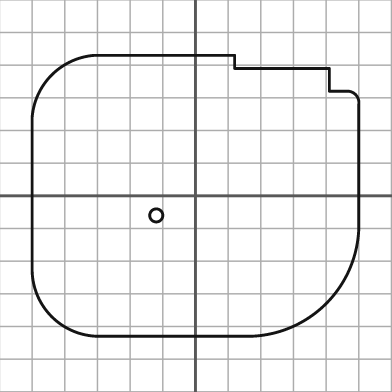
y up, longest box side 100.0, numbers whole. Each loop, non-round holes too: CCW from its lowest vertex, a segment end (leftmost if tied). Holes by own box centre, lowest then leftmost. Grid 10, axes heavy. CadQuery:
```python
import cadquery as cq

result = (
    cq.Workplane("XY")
    .moveTo(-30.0, -43.0)
    .lineTo(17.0, -43.0)
    .threePointArc((40.0, -33.0), (50.0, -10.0))
    .lineTo(50.0, 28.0)
    .threePointArc((49.0, 31.0), (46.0, 32.0))
    .lineTo(41.0, 32.0)
    .lineTo(41.0, 39.0)
    .lineTo(12.0, 39.0)
    .lineTo(12.0, 43.0)
    .lineTo(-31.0, 43.0)
    .threePointArc((-44.0, 37.0), (-50.0, 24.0))
    .lineTo(-50.0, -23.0)
    .threePointArc((-44.0, -37.0), (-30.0, -43.0))
    .close()
    .moveTo(-12.0, -6.0)
    .circle(2.0)
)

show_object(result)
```